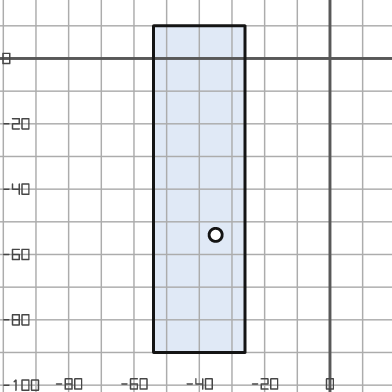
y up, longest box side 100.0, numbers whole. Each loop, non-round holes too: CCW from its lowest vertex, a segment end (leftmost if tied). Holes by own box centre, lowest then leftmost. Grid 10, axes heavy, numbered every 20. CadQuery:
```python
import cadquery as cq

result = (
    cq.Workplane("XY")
    .moveTo(-54.0, -90.0)
    .lineTo(-26.0, -90.0)
    .lineTo(-26.0, 10.0)
    .lineTo(-54.0, 10.0)
    .close()
    .moveTo(-35.0, -54.0)
    .circle(2.0)
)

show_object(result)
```